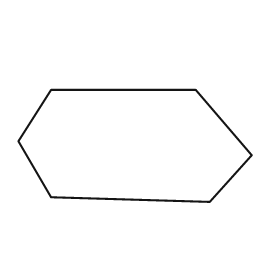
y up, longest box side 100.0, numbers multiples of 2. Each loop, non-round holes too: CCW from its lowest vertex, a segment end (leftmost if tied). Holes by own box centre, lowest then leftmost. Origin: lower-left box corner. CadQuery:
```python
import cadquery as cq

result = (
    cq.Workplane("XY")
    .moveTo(82.0, 0.0)
    .lineTo(100.0, 20.0)
    .lineTo(76.0, 48.0)
    .lineTo(14.0, 48.0)
    .lineTo(0.0, 26.0)
    .lineTo(14.0, 2.0)
    .close()
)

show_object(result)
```